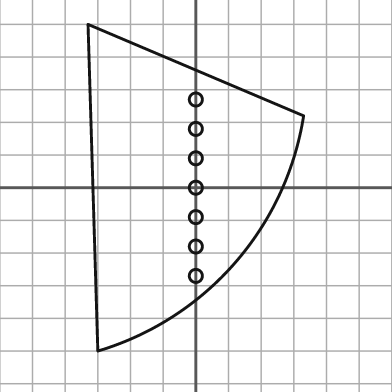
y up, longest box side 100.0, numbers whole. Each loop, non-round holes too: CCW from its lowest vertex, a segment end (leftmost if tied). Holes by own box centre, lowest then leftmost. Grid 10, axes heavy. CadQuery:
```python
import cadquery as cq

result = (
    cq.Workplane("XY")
    .moveTo(-30.0, -50.0)
    .threePointArc((12.0, -23.0), (33.0, 22.0))
    .lineTo(-33.0, 50.0)
    .close()
    .moveTo(0.0, -27.0)
    .circle(2.0)
    .moveTo(0.0, -18.0)
    .circle(2.0)
    .moveTo(0.0, -9.0)
    .circle(2.0)
    .moveTo(0.0, 0.0)
    .circle(2.0)
    .moveTo(0.0, 9.0)
    .circle(2.0)
    .moveTo(0.0, 18.0)
    .circle(2.0)
    .moveTo(0.0, 27.0)
    .circle(2.0)
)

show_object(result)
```